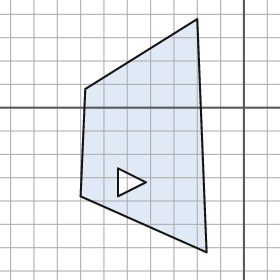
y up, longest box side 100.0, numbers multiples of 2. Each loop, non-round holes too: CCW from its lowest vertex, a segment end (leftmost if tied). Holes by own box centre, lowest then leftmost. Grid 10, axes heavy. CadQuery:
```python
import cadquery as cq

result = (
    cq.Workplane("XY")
    .moveTo(-16.0, -62.0)
    .lineTo(-20.0, 38.0)
    .lineTo(-68.0, 8.0)
    .lineTo(-70.0, -38.0)
    .close()
    .moveTo(-54.0, -38.0)
    .lineTo(-42.0, -32.0)
    .lineTo(-54.0, -26.0)
    .close()
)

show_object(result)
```